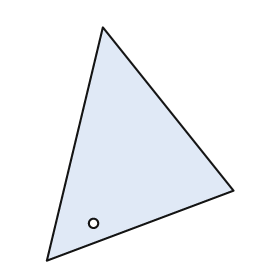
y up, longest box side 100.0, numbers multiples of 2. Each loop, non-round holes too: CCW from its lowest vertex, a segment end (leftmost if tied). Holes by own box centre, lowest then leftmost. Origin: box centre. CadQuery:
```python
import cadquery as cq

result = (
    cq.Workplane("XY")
    .moveTo(-40.0, -50.0)
    .lineTo(40.0, -20.0)
    .lineTo(-16.0, 50.0)
    .close()
    .moveTo(-20.0, -34.0)
    .circle(2.0)
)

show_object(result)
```